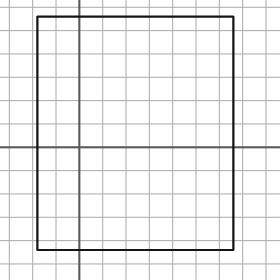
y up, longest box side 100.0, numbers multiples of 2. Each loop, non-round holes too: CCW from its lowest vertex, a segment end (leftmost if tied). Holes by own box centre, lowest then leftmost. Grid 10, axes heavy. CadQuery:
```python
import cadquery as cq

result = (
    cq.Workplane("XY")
    .moveTo(-18.0, -44.0)
    .lineTo(66.0, -44.0)
    .lineTo(66.0, 56.0)
    .lineTo(-18.0, 56.0)
    .close()
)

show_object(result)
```